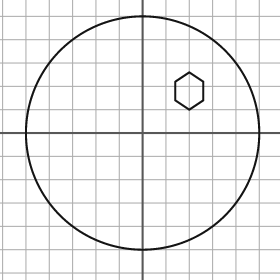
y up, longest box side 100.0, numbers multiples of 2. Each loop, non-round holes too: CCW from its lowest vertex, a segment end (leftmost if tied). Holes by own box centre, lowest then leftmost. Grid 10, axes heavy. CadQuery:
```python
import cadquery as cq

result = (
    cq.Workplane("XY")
    .moveTo(0.0, 0.0)
    .circle(50.0)
    .moveTo(20.0, 10.0)
    .lineTo(26.0, 14.0)
    .lineTo(26.0, 22.0)
    .lineTo(20.0, 26.0)
    .lineTo(14.0, 22.0)
    .lineTo(14.0, 14.0)
    .close()
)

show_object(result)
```